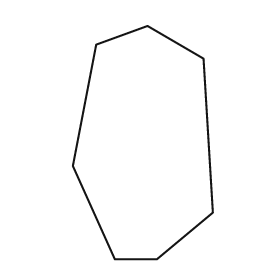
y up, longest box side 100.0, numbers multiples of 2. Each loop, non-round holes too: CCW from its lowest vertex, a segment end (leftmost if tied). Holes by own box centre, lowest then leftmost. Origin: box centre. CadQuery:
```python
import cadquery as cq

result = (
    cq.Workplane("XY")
    .moveTo(-12.0, -50.0)
    .lineTo(6.0, -50.0)
    .lineTo(30.0, -30.0)
    .lineTo(26.0, 36.0)
    .lineTo(2.0, 50.0)
    .lineTo(-20.0, 42.0)
    .lineTo(-30.0, -10.0)
    .close()
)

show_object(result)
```